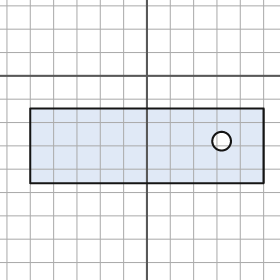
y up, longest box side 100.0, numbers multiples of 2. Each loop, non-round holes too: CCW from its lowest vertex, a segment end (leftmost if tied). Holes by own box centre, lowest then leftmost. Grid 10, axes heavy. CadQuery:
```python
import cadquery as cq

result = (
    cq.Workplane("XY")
    .moveTo(-50.0, -46.0)
    .lineTo(50.0, -46.0)
    .lineTo(50.0, -14.0)
    .lineTo(-50.0, -14.0)
    .close()
    .moveTo(32.0, -28.0)
    .circle(4.0)
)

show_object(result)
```